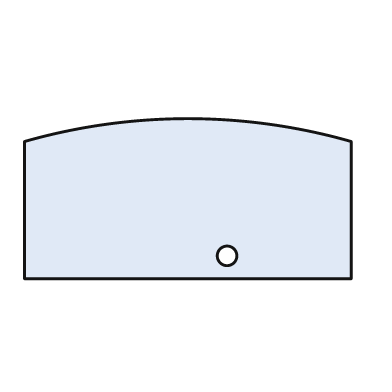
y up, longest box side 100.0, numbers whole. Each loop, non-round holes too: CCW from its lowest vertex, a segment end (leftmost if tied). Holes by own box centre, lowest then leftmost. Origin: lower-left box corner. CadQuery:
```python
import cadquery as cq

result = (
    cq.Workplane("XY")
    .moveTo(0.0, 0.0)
    .lineTo(100.0, 0.0)
    .lineTo(100.0, 42.0)
    .threePointArc((50.0, 49.0), (0.0, 42.0))
    .close()
    .moveTo(62.0, 7.0)
    .circle(3.0)
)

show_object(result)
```